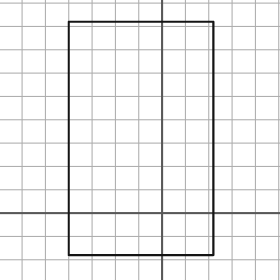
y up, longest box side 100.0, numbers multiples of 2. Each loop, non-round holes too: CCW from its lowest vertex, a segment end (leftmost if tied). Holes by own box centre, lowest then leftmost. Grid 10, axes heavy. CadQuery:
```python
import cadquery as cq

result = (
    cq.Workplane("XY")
    .moveTo(-40.0, -18.0)
    .lineTo(22.0, -18.0)
    .lineTo(22.0, 82.0)
    .lineTo(-40.0, 82.0)
    .close()
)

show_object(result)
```